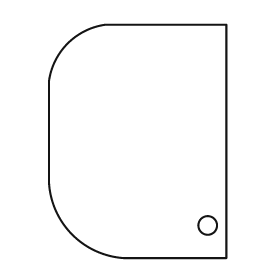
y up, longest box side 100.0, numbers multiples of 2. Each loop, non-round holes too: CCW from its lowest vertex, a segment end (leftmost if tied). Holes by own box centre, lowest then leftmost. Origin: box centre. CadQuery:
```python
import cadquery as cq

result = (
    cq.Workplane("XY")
    .moveTo(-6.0, -50.0)
    .lineTo(38.0, -50.0)
    .lineTo(38.0, 50.0)
    .lineTo(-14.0, 50.0)
    .threePointArc((-30.0, 42.0), (-38.0, 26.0))
    .lineTo(-38.0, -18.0)
    .threePointArc((-28.0, -40.0), (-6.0, -50.0))
    .close()
    .moveTo(30.0, -36.0)
    .circle(4.0)
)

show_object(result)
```